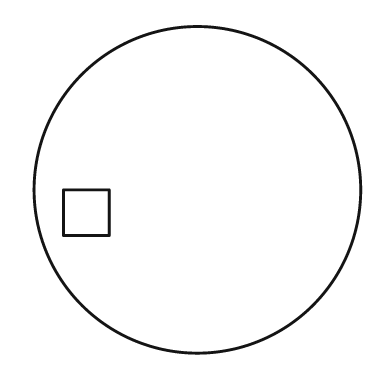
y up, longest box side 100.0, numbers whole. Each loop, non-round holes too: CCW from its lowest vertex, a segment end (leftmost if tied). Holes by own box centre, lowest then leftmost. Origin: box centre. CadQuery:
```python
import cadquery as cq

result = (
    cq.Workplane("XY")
    .moveTo(0.0, 0.0)
    .circle(50.0)
    .moveTo(-41.0, -14.0)
    .lineTo(-27.0, -14.0)
    .lineTo(-27.0, 0.0)
    .lineTo(-41.0, 0.0)
    .close()
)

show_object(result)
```